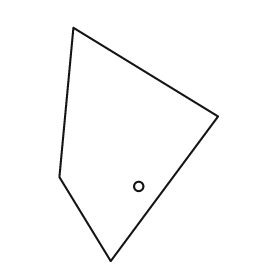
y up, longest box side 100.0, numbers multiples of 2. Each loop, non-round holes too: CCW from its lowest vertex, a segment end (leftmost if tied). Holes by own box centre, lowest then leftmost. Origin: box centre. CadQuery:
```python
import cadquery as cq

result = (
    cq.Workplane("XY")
    .moveTo(-12.0, -50.0)
    .lineTo(34.0, 12.0)
    .lineTo(-28.0, 50.0)
    .lineTo(-34.0, -14.0)
    .close()
    .moveTo(0.0, -18.0)
    .circle(2.0)
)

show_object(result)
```